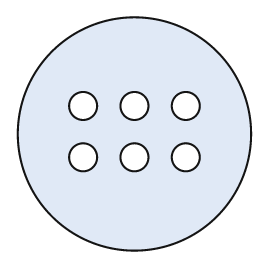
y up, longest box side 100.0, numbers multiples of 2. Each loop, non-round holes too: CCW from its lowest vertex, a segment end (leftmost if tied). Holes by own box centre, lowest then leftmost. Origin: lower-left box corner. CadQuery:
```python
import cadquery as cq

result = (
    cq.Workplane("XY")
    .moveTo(50.0, 50.0)
    .circle(50.0)
    .moveTo(28.0, 40.0)
    .circle(6.0)
    .moveTo(50.0, 40.0)
    .circle(6.0)
    .moveTo(72.0, 40.0)
    .circle(6.0)
    .moveTo(28.0, 62.0)
    .circle(6.0)
    .moveTo(50.0, 62.0)
    .circle(6.0)
    .moveTo(72.0, 62.0)
    .circle(6.0)
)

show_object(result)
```